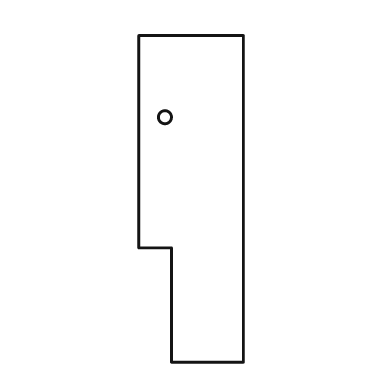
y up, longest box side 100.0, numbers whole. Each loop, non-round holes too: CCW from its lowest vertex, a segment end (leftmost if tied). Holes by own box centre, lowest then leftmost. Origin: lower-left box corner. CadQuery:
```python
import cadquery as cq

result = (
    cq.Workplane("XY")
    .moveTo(10.0, 0.0)
    .lineTo(32.0, 0.0)
    .lineTo(32.0, 100.0)
    .lineTo(0.0, 100.0)
    .lineTo(0.0, 35.0)
    .lineTo(10.0, 35.0)
    .close()
    .moveTo(8.0, 75.0)
    .circle(2.0)
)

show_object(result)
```